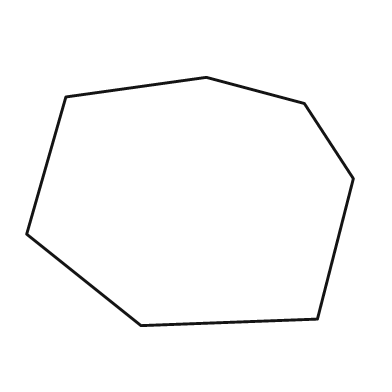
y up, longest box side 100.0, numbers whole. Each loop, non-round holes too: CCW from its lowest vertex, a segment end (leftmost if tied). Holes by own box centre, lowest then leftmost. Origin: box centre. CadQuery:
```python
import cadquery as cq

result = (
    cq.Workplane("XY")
    .moveTo(-15.0, -38.0)
    .lineTo(39.0, -36.0)
    .lineTo(50.0, 7.0)
    .lineTo(35.0, 30.0)
    .lineTo(5.0, 38.0)
    .lineTo(-38.0, 32.0)
    .lineTo(-50.0, -10.0)
    .close()
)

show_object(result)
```